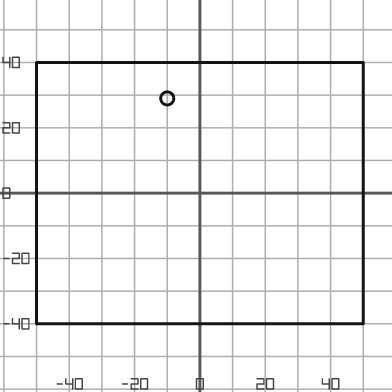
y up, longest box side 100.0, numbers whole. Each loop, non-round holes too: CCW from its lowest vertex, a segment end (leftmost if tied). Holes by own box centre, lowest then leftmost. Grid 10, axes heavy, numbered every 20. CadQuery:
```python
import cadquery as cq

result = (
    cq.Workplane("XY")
    .moveTo(-50.0, -40.0)
    .lineTo(50.0, -40.0)
    .lineTo(50.0, 40.0)
    .lineTo(-50.0, 40.0)
    .close()
    .moveTo(-10.0, 29.0)
    .circle(2.0)
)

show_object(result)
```